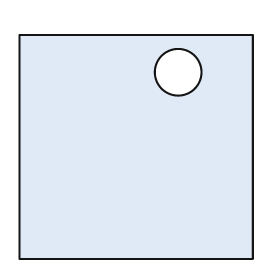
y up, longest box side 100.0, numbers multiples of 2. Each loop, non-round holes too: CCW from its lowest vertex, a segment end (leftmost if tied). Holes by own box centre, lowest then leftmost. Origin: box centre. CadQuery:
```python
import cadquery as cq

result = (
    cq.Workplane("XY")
    .moveTo(-50.0, -48.0)
    .lineTo(50.0, -48.0)
    .lineTo(50.0, 48.0)
    .lineTo(-50.0, 48.0)
    .close()
    .moveTo(18.0, 32.0)
    .circle(10.0)
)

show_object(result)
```